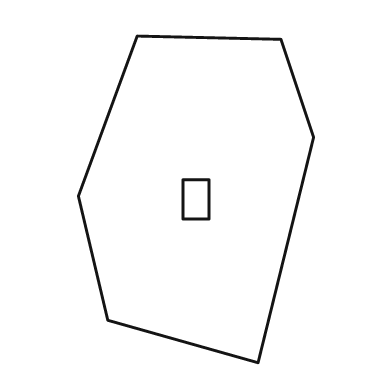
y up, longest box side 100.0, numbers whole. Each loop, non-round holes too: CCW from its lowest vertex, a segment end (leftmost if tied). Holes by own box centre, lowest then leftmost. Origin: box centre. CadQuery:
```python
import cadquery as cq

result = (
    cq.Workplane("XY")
    .moveTo(19.0, -50.0)
    .lineTo(36.0, 19.0)
    .lineTo(26.0, 49.0)
    .lineTo(-18.0, 50.0)
    .lineTo(-36.0, 1.0)
    .lineTo(-27.0, -37.0)
    .close()
    .moveTo(-4.0, -6.0)
    .lineTo(4.0, -6.0)
    .lineTo(4.0, 6.0)
    .lineTo(-4.0, 6.0)
    .close()
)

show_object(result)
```